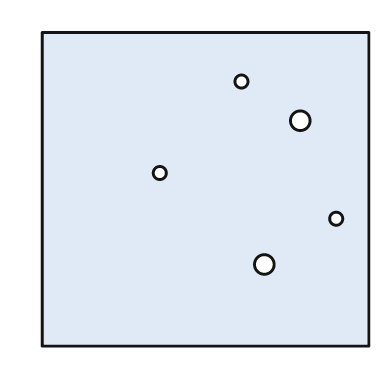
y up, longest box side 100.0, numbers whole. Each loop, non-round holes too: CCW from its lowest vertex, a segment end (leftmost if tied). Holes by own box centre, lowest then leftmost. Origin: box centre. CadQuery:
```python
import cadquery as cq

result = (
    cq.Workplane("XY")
    .moveTo(-50.0, -48.0)
    .lineTo(50.0, -48.0)
    .lineTo(50.0, 48.0)
    .lineTo(-50.0, 48.0)
    .close()
    .moveTo(18.0, -23.0)
    .circle(3.0)
    .moveTo(40.0, -9.0)
    .circle(2.0)
    .moveTo(-14.0, 5.0)
    .circle(2.0)
    .moveTo(29.0, 21.0)
    .circle(3.0)
    .moveTo(11.0, 33.0)
    .circle(2.0)
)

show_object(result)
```